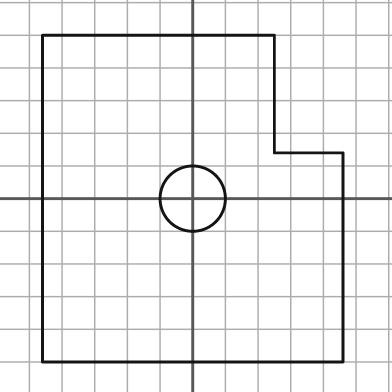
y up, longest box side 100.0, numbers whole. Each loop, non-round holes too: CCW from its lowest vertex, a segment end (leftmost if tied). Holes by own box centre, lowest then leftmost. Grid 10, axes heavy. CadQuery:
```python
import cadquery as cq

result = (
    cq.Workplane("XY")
    .moveTo(-46.0, -50.0)
    .lineTo(46.0, -50.0)
    .lineTo(46.0, 14.0)
    .lineTo(25.0, 14.0)
    .lineTo(25.0, 50.0)
    .lineTo(-46.0, 50.0)
    .close()
    .moveTo(0.0, 0.0)
    .circle(10.0)
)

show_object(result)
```